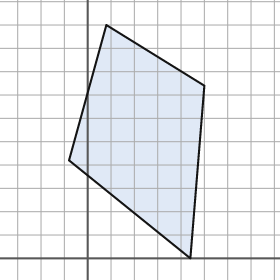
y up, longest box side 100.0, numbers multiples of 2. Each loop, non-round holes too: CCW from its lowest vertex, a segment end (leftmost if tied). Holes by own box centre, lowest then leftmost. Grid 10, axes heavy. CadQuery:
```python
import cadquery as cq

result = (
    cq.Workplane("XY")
    .moveTo(44.0, 0.0)
    .lineTo(50.0, 74.0)
    .lineTo(8.0, 100.0)
    .lineTo(-8.0, 42.0)
    .close()
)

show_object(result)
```